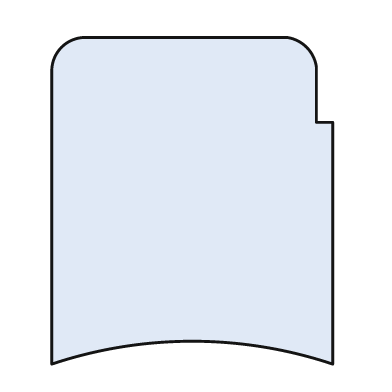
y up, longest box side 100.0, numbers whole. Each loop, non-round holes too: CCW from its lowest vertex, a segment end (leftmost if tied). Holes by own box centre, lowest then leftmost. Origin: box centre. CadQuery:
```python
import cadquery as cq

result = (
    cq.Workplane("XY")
    .moveTo(-43.0, -50.0)
    .threePointArc((0.0, -43.0), (43.0, -50.0))
    .lineTo(43.0, 24.0)
    .lineTo(38.0, 24.0)
    .lineTo(38.0, 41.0)
    .threePointArc((35.0, 47.0), (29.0, 50.0))
    .lineTo(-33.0, 50.0)
    .threePointArc((-40.0, 47.0), (-43.0, 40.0))
    .close()
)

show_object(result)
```